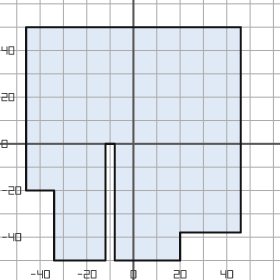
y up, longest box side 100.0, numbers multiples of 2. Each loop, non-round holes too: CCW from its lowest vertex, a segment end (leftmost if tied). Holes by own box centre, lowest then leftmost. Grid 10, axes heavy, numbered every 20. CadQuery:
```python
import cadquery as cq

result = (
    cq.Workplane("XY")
    .moveTo(-34.0, -50.0)
    .lineTo(-12.0, -50.0)
    .lineTo(-12.0, 0.0)
    .lineTo(-8.0, 0.0)
    .lineTo(-8.0, -50.0)
    .lineTo(20.0, -50.0)
    .lineTo(20.0, -38.0)
    .lineTo(46.0, -38.0)
    .lineTo(46.0, 50.0)
    .lineTo(-46.0, 50.0)
    .lineTo(-46.0, -20.0)
    .lineTo(-34.0, -20.0)
    .close()
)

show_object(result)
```